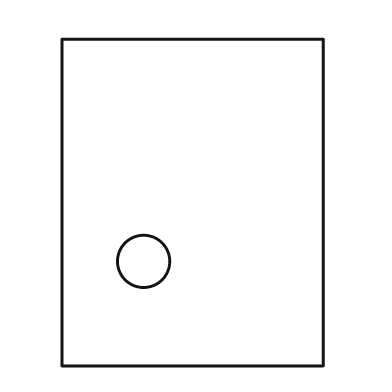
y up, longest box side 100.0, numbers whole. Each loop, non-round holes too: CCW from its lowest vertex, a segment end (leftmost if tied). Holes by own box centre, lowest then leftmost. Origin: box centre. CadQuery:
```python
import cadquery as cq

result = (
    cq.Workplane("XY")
    .moveTo(-40.0, -50.0)
    .lineTo(40.0, -50.0)
    .lineTo(40.0, 50.0)
    .lineTo(-40.0, 50.0)
    .close()
    .moveTo(-15.0, -18.0)
    .circle(8.0)
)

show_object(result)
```